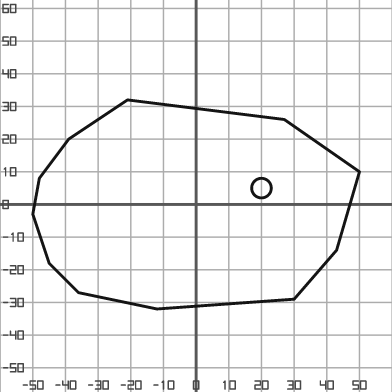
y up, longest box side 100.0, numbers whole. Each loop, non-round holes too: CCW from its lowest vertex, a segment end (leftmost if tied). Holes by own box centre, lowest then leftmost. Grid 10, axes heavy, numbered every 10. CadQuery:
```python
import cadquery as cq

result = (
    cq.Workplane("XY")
    .moveTo(-12.0, -32.0)
    .lineTo(30.0, -29.0)
    .lineTo(43.0, -14.0)
    .lineTo(50.0, 10.0)
    .lineTo(27.0, 26.0)
    .lineTo(-21.0, 32.0)
    .lineTo(-39.0, 20.0)
    .lineTo(-48.0, 8.0)
    .lineTo(-50.0, -3.0)
    .lineTo(-45.0, -18.0)
    .lineTo(-36.0, -27.0)
    .close()
    .moveTo(20.0, 5.0)
    .circle(3.0)
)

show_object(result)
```